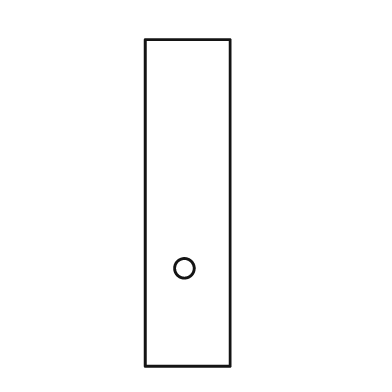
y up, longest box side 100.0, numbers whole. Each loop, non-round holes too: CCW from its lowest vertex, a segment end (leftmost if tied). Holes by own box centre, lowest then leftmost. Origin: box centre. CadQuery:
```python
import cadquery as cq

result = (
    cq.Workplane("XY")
    .moveTo(-13.0, -50.0)
    .lineTo(13.0, -50.0)
    .lineTo(13.0, 50.0)
    .lineTo(-13.0, 50.0)
    .close()
    .moveTo(-1.0, -20.0)
    .circle(3.0)
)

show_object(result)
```